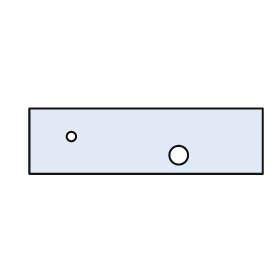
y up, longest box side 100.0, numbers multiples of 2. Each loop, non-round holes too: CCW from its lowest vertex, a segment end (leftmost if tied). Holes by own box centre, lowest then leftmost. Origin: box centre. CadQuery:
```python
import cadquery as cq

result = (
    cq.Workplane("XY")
    .moveTo(-50.0, -14.0)
    .lineTo(50.0, -14.0)
    .lineTo(50.0, 14.0)
    .lineTo(-50.0, 14.0)
    .close()
    .moveTo(14.0, -6.0)
    .circle(4.0)
    .moveTo(-32.0, 2.0)
    .circle(2.0)
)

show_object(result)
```